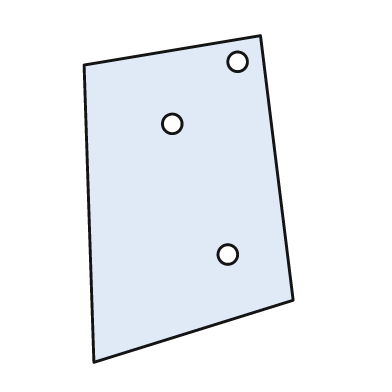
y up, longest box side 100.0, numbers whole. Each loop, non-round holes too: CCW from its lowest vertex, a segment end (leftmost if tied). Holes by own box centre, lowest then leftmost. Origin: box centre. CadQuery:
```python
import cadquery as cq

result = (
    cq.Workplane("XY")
    .moveTo(-29.0, -50.0)
    .lineTo(32.0, -31.0)
    .lineTo(22.0, 50.0)
    .lineTo(-32.0, 41.0)
    .close()
    .moveTo(12.0, -17.0)
    .circle(3.0)
    .moveTo(-5.0, 23.0)
    .circle(3.0)
    .moveTo(15.0, 42.0)
    .circle(3.0)
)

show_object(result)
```